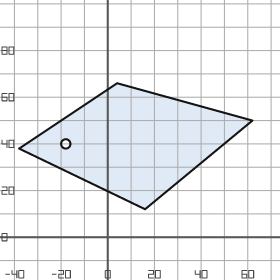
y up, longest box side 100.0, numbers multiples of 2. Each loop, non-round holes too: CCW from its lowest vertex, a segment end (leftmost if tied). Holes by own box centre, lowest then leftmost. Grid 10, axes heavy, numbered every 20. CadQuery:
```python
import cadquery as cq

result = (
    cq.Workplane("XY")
    .moveTo(16.0, 12.0)
    .lineTo(62.0, 50.0)
    .lineTo(4.0, 66.0)
    .lineTo(-38.0, 38.0)
    .close()
    .moveTo(-18.0, 40.0)
    .circle(2.0)
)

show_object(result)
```